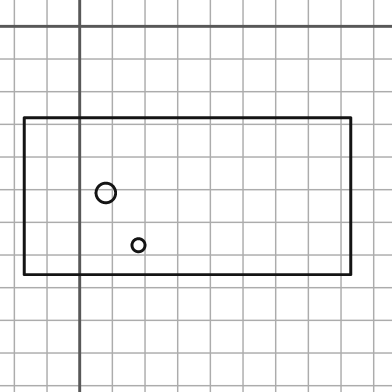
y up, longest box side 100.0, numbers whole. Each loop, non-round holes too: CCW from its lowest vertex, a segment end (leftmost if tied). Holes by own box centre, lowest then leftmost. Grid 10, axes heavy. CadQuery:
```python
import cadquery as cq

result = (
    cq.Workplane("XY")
    .moveTo(-17.0, -76.0)
    .lineTo(83.0, -76.0)
    .lineTo(83.0, -28.0)
    .lineTo(-17.0, -28.0)
    .close()
    .moveTo(18.0, -67.0)
    .circle(2.0)
    .moveTo(8.0, -51.0)
    .circle(3.0)
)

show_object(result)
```